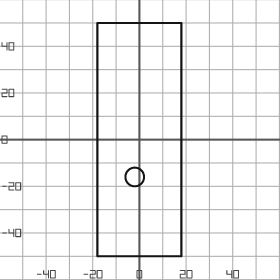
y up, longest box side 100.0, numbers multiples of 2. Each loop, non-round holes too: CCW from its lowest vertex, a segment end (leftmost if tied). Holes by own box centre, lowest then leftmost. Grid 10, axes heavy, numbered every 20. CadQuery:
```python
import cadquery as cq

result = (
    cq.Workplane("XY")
    .moveTo(-18.0, -50.0)
    .lineTo(18.0, -50.0)
    .lineTo(18.0, 50.0)
    .lineTo(-18.0, 50.0)
    .close()
    .moveTo(-2.0, -16.0)
    .circle(4.0)
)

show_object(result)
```